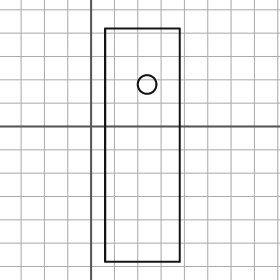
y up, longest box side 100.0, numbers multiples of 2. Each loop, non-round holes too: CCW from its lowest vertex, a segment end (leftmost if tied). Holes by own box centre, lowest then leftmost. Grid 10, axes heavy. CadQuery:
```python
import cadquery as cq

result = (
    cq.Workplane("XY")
    .moveTo(6.0, -58.0)
    .lineTo(38.0, -58.0)
    .lineTo(38.0, 42.0)
    .lineTo(6.0, 42.0)
    .close()
    .moveTo(24.0, 18.0)
    .circle(4.0)
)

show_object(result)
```